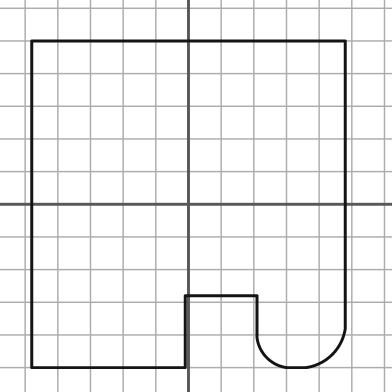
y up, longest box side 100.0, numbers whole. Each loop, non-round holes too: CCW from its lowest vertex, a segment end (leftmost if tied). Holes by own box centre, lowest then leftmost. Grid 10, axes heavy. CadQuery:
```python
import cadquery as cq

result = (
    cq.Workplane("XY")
    .moveTo(-48.0, -50.0)
    .lineTo(-1.0, -50.0)
    .lineTo(-1.0, -28.0)
    .lineTo(21.0, -28.0)
    .lineTo(21.0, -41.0)
    .threePointArc((24.0, -47.0), (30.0, -50.0))
    .lineTo(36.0, -50.0)
    .threePointArc((44.0, -46.0), (48.0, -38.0))
    .lineTo(48.0, 50.0)
    .lineTo(-48.0, 50.0)
    .close()
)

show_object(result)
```